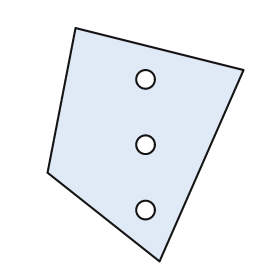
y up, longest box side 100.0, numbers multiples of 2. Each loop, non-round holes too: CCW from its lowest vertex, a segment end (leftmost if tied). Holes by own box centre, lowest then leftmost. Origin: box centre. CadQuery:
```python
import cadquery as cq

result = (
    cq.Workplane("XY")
    .moveTo(6.0, -50.0)
    .lineTo(42.0, 32.0)
    .lineTo(-30.0, 50.0)
    .lineTo(-42.0, -12.0)
    .close()
    .moveTo(0.0, -28.0)
    .circle(4.0)
    .moveTo(0.0, 0.0)
    .circle(4.0)
    .moveTo(0.0, 28.0)
    .circle(4.0)
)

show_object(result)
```